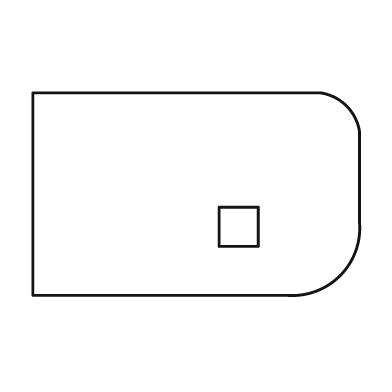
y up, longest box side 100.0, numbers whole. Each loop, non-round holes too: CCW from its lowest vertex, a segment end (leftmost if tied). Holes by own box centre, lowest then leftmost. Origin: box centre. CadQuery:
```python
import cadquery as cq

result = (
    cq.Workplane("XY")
    .moveTo(-50.0, -31.0)
    .lineTo(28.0, -31.0)
    .threePointArc((44.0, -25.0), (50.0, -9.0))
    .lineTo(50.0, 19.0)
    .threePointArc((46.0, 27.0), (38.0, 31.0))
    .lineTo(-50.0, 31.0)
    .close()
    .moveTo(7.0, -16.0)
    .lineTo(19.0, -16.0)
    .lineTo(19.0, -4.0)
    .lineTo(7.0, -4.0)
    .close()
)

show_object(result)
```